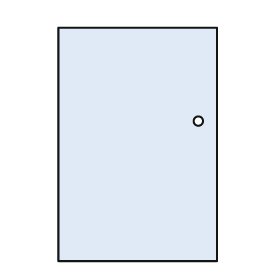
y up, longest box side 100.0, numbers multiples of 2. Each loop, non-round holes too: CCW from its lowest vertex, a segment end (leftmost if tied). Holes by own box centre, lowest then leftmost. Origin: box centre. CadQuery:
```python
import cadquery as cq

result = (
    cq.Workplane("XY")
    .moveTo(-34.0, -50.0)
    .lineTo(34.0, -50.0)
    .lineTo(34.0, 50.0)
    .lineTo(-34.0, 50.0)
    .close()
    .moveTo(26.0, 10.0)
    .circle(2.0)
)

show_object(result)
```